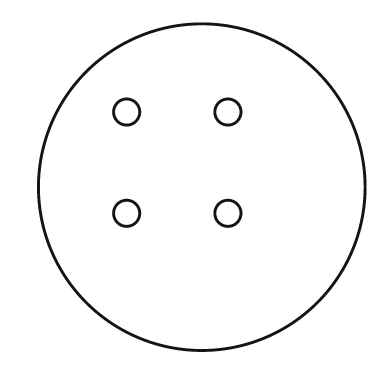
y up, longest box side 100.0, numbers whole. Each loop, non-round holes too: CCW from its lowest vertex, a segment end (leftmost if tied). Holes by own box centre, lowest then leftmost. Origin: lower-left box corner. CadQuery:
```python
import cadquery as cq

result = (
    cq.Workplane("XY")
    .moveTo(50.0, 50.0)
    .circle(50.0)
    .moveTo(27.0, 42.0)
    .circle(4.0)
    .moveTo(58.0, 42.0)
    .circle(4.0)
    .moveTo(27.0, 73.0)
    .circle(4.0)
    .moveTo(58.0, 73.0)
    .circle(4.0)
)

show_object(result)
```